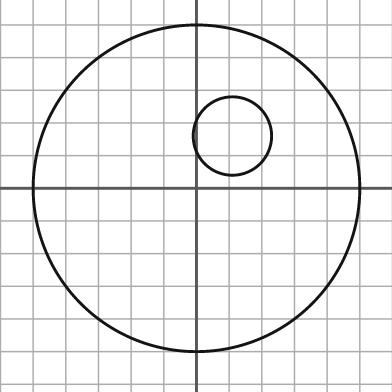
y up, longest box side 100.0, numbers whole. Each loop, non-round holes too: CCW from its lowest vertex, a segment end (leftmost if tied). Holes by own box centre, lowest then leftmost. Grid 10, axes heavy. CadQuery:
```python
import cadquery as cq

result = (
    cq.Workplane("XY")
    .moveTo(0.0, 0.0)
    .circle(50.0)
    .moveTo(11.0, 16.0)
    .circle(12.0)
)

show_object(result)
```